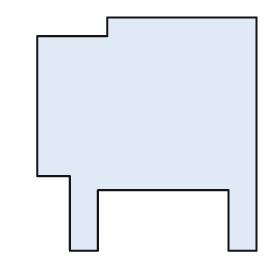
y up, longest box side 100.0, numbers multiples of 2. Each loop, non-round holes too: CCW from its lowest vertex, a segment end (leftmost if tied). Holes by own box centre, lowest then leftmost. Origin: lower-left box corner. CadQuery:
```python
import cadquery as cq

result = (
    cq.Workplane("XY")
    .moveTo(14.0, 0.0)
    .lineTo(26.0, 0.0)
    .lineTo(26.0, 26.0)
    .lineTo(82.0, 26.0)
    .lineTo(82.0, 0.0)
    .lineTo(94.0, 0.0)
    .lineTo(94.0, 100.0)
    .lineTo(30.0, 100.0)
    .lineTo(30.0, 92.0)
    .lineTo(0.0, 92.0)
    .lineTo(0.0, 32.0)
    .lineTo(14.0, 32.0)
    .close()
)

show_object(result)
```